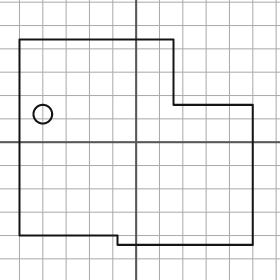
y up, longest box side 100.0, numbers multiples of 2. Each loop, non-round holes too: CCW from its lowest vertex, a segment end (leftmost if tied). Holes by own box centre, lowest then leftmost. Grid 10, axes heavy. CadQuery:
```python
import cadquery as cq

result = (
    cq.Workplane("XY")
    .moveTo(-8.0, -44.0)
    .lineTo(50.0, -44.0)
    .lineTo(50.0, 16.0)
    .lineTo(16.0, 16.0)
    .lineTo(16.0, 44.0)
    .lineTo(-50.0, 44.0)
    .lineTo(-50.0, -40.0)
    .lineTo(-8.0, -40.0)
    .close()
    .moveTo(-40.0, 12.0)
    .circle(4.0)
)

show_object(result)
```